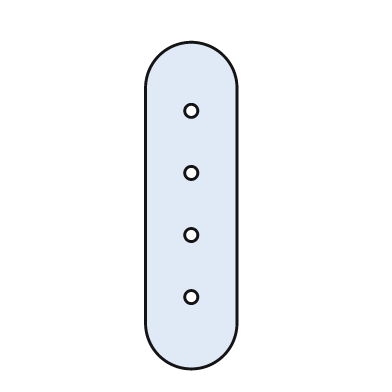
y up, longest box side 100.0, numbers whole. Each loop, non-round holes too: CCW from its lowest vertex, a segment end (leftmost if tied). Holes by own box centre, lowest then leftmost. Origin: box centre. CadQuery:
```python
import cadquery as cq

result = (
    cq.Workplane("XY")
    .moveTo(-14.0, -36.0)
    .threePointArc((0.0, -50.0), (14.0, -36.0))
    .lineTo(14.0, 36.0)
    .threePointArc((0.0, 50.0), (-14.0, 36.0))
    .close()
    .moveTo(0.0, -28.0)
    .circle(2.0)
    .moveTo(0.0, -9.0)
    .circle(2.0)
    .moveTo(0.0, 10.0)
    .circle(2.0)
    .moveTo(0.0, 29.0)
    .circle(2.0)
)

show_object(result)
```